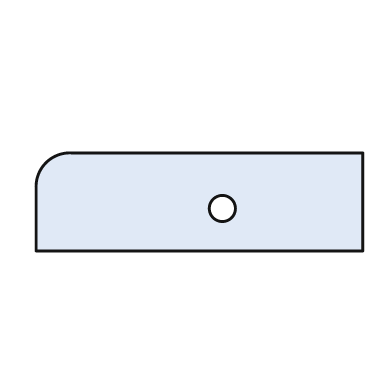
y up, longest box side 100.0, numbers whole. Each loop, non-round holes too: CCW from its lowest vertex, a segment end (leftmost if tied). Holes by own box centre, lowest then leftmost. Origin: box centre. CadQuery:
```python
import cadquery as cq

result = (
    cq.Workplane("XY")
    .moveTo(-50.0, -15.0)
    .lineTo(50.0, -15.0)
    .lineTo(50.0, 15.0)
    .lineTo(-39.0, 15.0)
    .threePointArc((-47.0, 12.0), (-50.0, 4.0))
    .close()
    .moveTo(7.0, -2.0)
    .circle(4.0)
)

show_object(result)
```